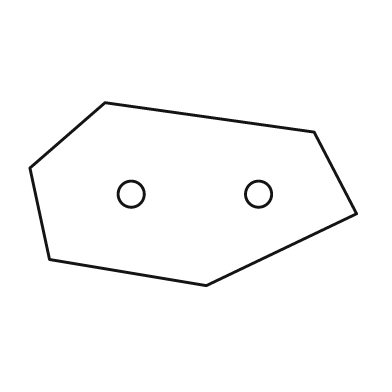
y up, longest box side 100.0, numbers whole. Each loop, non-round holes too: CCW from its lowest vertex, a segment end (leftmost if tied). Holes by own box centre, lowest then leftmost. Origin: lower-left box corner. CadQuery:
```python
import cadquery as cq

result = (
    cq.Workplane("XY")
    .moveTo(54.0, 0.0)
    .lineTo(100.0, 22.0)
    .lineTo(87.0, 47.0)
    .lineTo(23.0, 56.0)
    .lineTo(0.0, 36.0)
    .lineTo(6.0, 8.0)
    .close()
    .moveTo(31.0, 28.0)
    .circle(4.0)
    .moveTo(70.0, 28.0)
    .circle(4.0)
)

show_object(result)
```